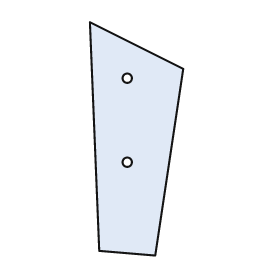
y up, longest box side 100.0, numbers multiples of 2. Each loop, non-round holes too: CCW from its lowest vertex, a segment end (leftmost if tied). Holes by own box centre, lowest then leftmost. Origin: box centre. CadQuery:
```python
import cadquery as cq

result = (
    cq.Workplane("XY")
    .moveTo(8.0, -50.0)
    .lineTo(20.0, 30.0)
    .lineTo(-20.0, 50.0)
    .lineTo(-16.0, -48.0)
    .close()
    .moveTo(-4.0, -10.0)
    .circle(2.0)
    .moveTo(-4.0, 26.0)
    .circle(2.0)
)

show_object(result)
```